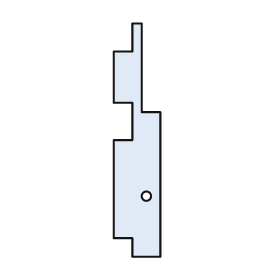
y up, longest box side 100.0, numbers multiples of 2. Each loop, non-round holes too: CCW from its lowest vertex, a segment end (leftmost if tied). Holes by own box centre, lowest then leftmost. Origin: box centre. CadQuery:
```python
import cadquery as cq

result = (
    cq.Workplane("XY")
    .moveTo(-2.0, -50.0)
    .lineTo(10.0, -50.0)
    .lineTo(10.0, 12.0)
    .lineTo(2.0, 12.0)
    .lineTo(2.0, 50.0)
    .lineTo(-2.0, 50.0)
    .lineTo(-2.0, 38.0)
    .lineTo(-10.0, 38.0)
    .lineTo(-10.0, 16.0)
    .lineTo(-2.0, 16.0)
    .lineTo(-2.0, 0.0)
    .lineTo(-10.0, 0.0)
    .lineTo(-10.0, -42.0)
    .lineTo(-2.0, -42.0)
    .close()
    .moveTo(4.0, -24.0)
    .circle(2.0)
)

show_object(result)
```